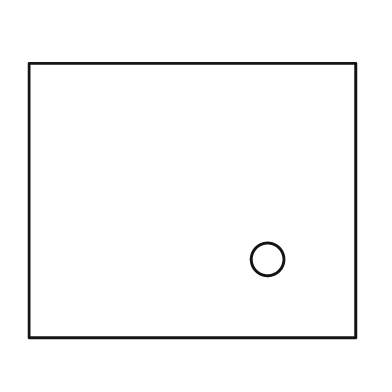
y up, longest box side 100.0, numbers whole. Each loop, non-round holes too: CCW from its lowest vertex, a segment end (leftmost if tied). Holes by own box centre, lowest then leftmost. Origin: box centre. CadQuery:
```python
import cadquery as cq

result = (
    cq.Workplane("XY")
    .moveTo(-50.0, -42.0)
    .lineTo(50.0, -42.0)
    .lineTo(50.0, 42.0)
    .lineTo(-50.0, 42.0)
    .close()
    .moveTo(23.0, -18.0)
    .circle(5.0)
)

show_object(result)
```